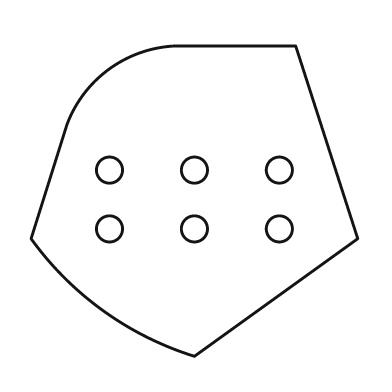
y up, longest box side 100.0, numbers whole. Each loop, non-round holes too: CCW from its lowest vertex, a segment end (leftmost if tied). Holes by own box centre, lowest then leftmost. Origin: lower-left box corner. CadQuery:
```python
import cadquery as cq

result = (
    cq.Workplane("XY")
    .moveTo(50.0, 0.0)
    .lineTo(100.0, 36.0)
    .lineTo(81.0, 95.0)
    .lineTo(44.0, 95.0)
    .threePointArc((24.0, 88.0), (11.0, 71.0))
    .lineTo(0.0, 36.0)
    .threePointArc((22.0, 14.0), (50.0, 0.0))
    .close()
    .moveTo(24.0, 39.0)
    .circle(4.0)
    .moveTo(50.0, 39.0)
    .circle(4.0)
    .moveTo(76.0, 39.0)
    .circle(4.0)
    .moveTo(24.0, 57.0)
    .circle(4.0)
    .moveTo(50.0, 57.0)
    .circle(4.0)
    .moveTo(76.0, 57.0)
    .circle(4.0)
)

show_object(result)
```